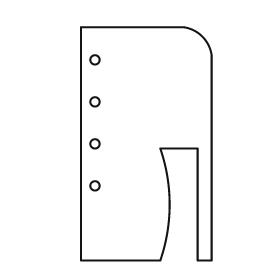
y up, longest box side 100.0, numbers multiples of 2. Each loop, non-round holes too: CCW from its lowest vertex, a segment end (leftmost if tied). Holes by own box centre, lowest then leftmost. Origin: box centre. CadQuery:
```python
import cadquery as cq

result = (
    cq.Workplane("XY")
    .moveTo(-28.0, -50.0)
    .lineTo(6.0, -50.0)
    .threePointArc((10.0, -26.0), (6.0, -2.0))
    .lineTo(22.0, -2.0)
    .lineTo(22.0, -50.0)
    .lineTo(28.0, -50.0)
    .lineTo(28.0, 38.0)
    .threePointArc((24.0, 46.0), (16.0, 50.0))
    .lineTo(-28.0, 50.0)
    .close()
    .moveTo(-22.0, -18.0)
    .circle(2.0)
    .moveTo(-22.0, 0.0)
    .circle(2.0)
    .moveTo(-22.0, 18.0)
    .circle(2.0)
    .moveTo(-22.0, 36.0)
    .circle(2.0)
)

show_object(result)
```